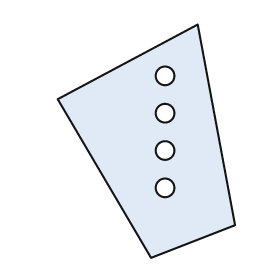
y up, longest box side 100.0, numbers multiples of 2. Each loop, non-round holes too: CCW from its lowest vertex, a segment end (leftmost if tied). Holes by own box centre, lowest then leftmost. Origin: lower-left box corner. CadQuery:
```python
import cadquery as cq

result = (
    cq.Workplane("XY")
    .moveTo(40.0, 0.0)
    .lineTo(76.0, 14.0)
    .lineTo(60.0, 100.0)
    .lineTo(0.0, 68.0)
    .close()
    .moveTo(46.0, 30.0)
    .circle(4.0)
    .moveTo(46.0, 46.0)
    .circle(4.0)
    .moveTo(46.0, 62.0)
    .circle(4.0)
    .moveTo(46.0, 78.0)
    .circle(4.0)
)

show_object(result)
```